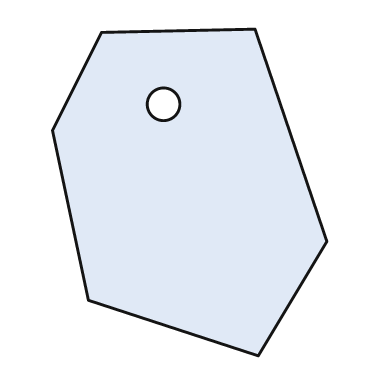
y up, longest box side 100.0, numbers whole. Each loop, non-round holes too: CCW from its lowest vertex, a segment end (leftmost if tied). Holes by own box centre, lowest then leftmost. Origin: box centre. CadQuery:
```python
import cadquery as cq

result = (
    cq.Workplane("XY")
    .moveTo(21.0, -50.0)
    .lineTo(42.0, -15.0)
    .lineTo(20.0, 50.0)
    .lineTo(-27.0, 49.0)
    .lineTo(-42.0, 19.0)
    .lineTo(-31.0, -33.0)
    .close()
    .moveTo(-8.0, 27.0)
    .circle(5.0)
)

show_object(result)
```